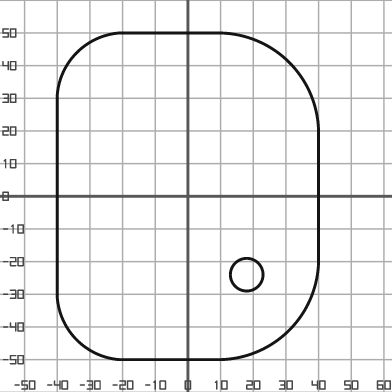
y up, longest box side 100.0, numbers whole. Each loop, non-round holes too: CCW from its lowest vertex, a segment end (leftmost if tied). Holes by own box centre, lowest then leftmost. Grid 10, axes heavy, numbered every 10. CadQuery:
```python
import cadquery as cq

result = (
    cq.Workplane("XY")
    .moveTo(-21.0, -50.0)
    .lineTo(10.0, -50.0)
    .threePointArc((31.0, -41.0), (40.0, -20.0))
    .lineTo(40.0, 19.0)
    .threePointArc((31.0, 41.0), (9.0, 50.0))
    .lineTo(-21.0, 50.0)
    .threePointArc((-34.0, 44.0), (-40.0, 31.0))
    .lineTo(-40.0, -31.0)
    .threePointArc((-34.0, -44.0), (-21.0, -50.0))
    .close()
    .moveTo(18.0, -24.0)
    .circle(5.0)
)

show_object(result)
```